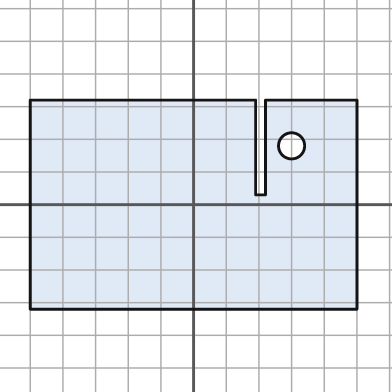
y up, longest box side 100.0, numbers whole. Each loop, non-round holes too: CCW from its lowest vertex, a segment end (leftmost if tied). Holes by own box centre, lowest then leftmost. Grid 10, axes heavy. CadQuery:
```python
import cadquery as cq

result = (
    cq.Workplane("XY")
    .moveTo(-50.0, -32.0)
    .lineTo(50.0, -32.0)
    .lineTo(50.0, 32.0)
    .lineTo(22.0, 32.0)
    .lineTo(22.0, 3.0)
    .lineTo(19.0, 3.0)
    .lineTo(19.0, 32.0)
    .lineTo(-50.0, 32.0)
    .close()
    .moveTo(30.0, 18.0)
    .circle(4.0)
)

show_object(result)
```